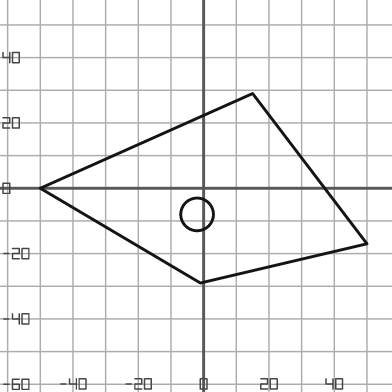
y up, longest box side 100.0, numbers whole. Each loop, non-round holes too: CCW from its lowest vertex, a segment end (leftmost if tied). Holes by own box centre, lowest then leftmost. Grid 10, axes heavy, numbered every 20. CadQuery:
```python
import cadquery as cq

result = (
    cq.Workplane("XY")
    .moveTo(-1.0, -29.0)
    .lineTo(50.0, -17.0)
    .lineTo(15.0, 29.0)
    .lineTo(-50.0, 0.0)
    .close()
    .moveTo(-2.0, -8.0)
    .circle(5.0)
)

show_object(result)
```